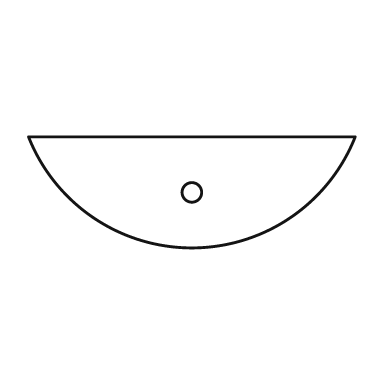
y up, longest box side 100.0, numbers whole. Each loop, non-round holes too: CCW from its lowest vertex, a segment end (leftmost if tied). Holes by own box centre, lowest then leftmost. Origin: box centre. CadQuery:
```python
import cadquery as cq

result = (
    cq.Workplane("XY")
    .moveTo(-50.0, 17.0)
    .threePointArc((0.0, -17.0), (50.0, 17.0))
    .close()
    .moveTo(0.0, 0.0)
    .circle(3.0)
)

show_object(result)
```